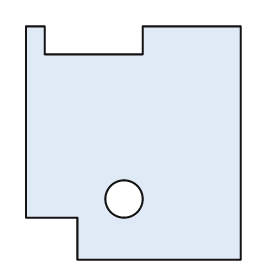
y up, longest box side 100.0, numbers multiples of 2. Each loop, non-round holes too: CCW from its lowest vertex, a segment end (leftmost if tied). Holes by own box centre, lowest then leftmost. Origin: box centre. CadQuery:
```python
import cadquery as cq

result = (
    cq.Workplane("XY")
    .moveTo(-24.0, -50.0)
    .lineTo(46.0, -50.0)
    .lineTo(46.0, 50.0)
    .lineTo(4.0, 50.0)
    .lineTo(4.0, 38.0)
    .lineTo(-38.0, 38.0)
    .lineTo(-38.0, 50.0)
    .lineTo(-46.0, 50.0)
    .lineTo(-46.0, -32.0)
    .lineTo(-24.0, -32.0)
    .close()
    .moveTo(-4.0, -24.0)
    .circle(8.0)
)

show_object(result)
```